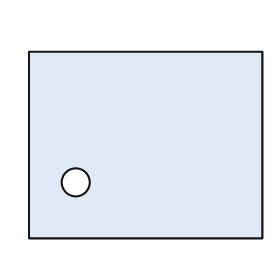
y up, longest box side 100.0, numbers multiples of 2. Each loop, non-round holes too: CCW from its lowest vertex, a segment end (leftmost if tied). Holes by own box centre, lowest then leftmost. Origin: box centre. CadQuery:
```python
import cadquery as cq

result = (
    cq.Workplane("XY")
    .moveTo(-50.0, -40.0)
    .lineTo(50.0, -40.0)
    .lineTo(50.0, 40.0)
    .lineTo(-50.0, 40.0)
    .close()
    .moveTo(-30.0, -16.0)
    .circle(6.0)
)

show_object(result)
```